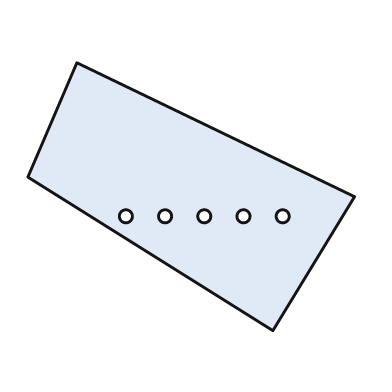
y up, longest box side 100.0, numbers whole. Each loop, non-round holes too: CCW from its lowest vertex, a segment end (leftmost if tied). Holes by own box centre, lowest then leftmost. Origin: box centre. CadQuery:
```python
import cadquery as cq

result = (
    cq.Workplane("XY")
    .moveTo(25.0, -41.0)
    .lineTo(50.0, 0.0)
    .lineTo(-35.0, 41.0)
    .lineTo(-50.0, 6.0)
    .close()
    .moveTo(-20.0, -6.0)
    .circle(2.0)
    .moveTo(-8.0, -6.0)
    .circle(2.0)
    .moveTo(4.0, -6.0)
    .circle(2.0)
    .moveTo(16.0, -6.0)
    .circle(2.0)
    .moveTo(28.0, -6.0)
    .circle(2.0)
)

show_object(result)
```